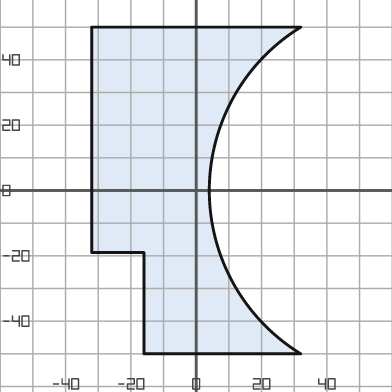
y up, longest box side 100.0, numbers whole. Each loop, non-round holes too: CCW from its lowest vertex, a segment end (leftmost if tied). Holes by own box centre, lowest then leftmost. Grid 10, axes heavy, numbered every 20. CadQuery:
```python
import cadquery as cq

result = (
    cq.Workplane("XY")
    .moveTo(-16.0, -50.0)
    .lineTo(32.0, -50.0)
    .threePointArc((4.0, 0.0), (32.0, 50.0))
    .lineTo(-32.0, 50.0)
    .lineTo(-32.0, -19.0)
    .lineTo(-16.0, -19.0)
    .close()
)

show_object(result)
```